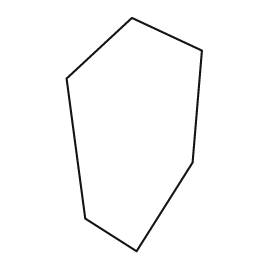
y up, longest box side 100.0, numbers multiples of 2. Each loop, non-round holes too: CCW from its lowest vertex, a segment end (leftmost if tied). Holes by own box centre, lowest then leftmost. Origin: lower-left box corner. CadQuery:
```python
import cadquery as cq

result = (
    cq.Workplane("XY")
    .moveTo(30.0, 0.0)
    .lineTo(54.0, 38.0)
    .lineTo(58.0, 86.0)
    .lineTo(28.0, 100.0)
    .lineTo(0.0, 74.0)
    .lineTo(8.0, 14.0)
    .close()
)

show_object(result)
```